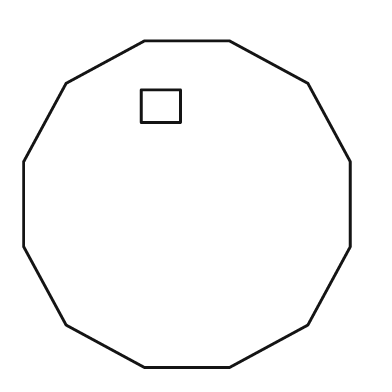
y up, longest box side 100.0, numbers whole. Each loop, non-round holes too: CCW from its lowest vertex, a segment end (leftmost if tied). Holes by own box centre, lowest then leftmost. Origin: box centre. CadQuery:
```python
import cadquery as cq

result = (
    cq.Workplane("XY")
    .moveTo(-13.0, -50.0)
    .lineTo(13.0, -50.0)
    .lineTo(37.0, -37.0)
    .lineTo(50.0, -13.0)
    .lineTo(50.0, 13.0)
    .lineTo(37.0, 37.0)
    .lineTo(13.0, 50.0)
    .lineTo(-13.0, 50.0)
    .lineTo(-37.0, 37.0)
    .lineTo(-50.0, 13.0)
    .lineTo(-50.0, -13.0)
    .lineTo(-37.0, -37.0)
    .close()
    .moveTo(-14.0, 25.0)
    .lineTo(-2.0, 25.0)
    .lineTo(-2.0, 35.0)
    .lineTo(-14.0, 35.0)
    .close()
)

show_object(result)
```